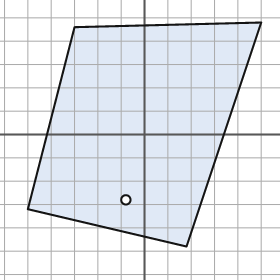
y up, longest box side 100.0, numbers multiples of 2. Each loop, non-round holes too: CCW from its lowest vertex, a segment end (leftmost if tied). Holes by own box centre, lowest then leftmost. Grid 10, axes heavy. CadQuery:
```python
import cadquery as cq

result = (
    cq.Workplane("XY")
    .moveTo(18.0, -48.0)
    .lineTo(50.0, 48.0)
    .lineTo(-30.0, 46.0)
    .lineTo(-50.0, -32.0)
    .close()
    .moveTo(-8.0, -28.0)
    .circle(2.0)
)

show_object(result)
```